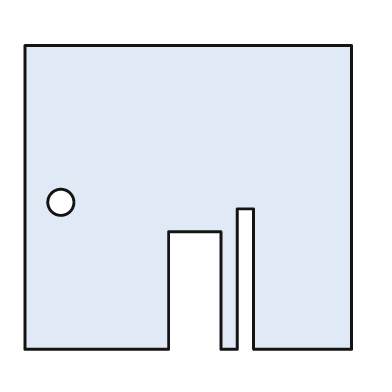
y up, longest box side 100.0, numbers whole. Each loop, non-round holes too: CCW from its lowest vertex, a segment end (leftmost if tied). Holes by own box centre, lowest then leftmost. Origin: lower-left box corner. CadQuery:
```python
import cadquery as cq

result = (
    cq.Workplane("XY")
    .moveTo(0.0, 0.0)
    .lineTo(44.0, 0.0)
    .lineTo(44.0, 36.0)
    .lineTo(60.0, 36.0)
    .lineTo(60.0, 0.0)
    .lineTo(65.0, 0.0)
    .lineTo(65.0, 43.0)
    .lineTo(70.0, 43.0)
    .lineTo(70.0, 0.0)
    .lineTo(100.0, 0.0)
    .lineTo(100.0, 93.0)
    .lineTo(0.0, 93.0)
    .close()
    .moveTo(11.0, 45.0)
    .circle(4.0)
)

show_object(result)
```